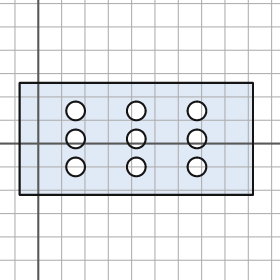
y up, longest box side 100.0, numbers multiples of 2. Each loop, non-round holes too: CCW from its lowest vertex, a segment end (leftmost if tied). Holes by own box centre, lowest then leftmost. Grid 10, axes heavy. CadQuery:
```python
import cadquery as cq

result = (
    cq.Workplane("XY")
    .moveTo(-8.0, -22.0)
    .lineTo(92.0, -22.0)
    .lineTo(92.0, 26.0)
    .lineTo(-8.0, 26.0)
    .close()
    .moveTo(16.0, -10.0)
    .circle(4.0)
    .moveTo(42.0, -10.0)
    .circle(4.0)
    .moveTo(68.0, -10.0)
    .circle(4.0)
    .moveTo(16.0, 2.0)
    .circle(4.0)
    .moveTo(42.0, 2.0)
    .circle(4.0)
    .moveTo(68.0, 2.0)
    .circle(4.0)
    .moveTo(16.0, 14.0)
    .circle(4.0)
    .moveTo(42.0, 14.0)
    .circle(4.0)
    .moveTo(68.0, 14.0)
    .circle(4.0)
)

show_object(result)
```